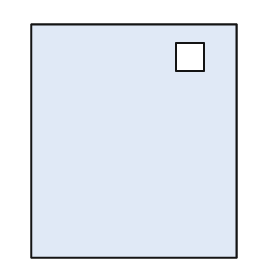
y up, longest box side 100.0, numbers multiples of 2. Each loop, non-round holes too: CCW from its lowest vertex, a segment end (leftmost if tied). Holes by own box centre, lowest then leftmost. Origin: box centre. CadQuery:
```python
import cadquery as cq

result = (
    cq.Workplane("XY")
    .moveTo(-44.0, -50.0)
    .lineTo(44.0, -50.0)
    .lineTo(44.0, 50.0)
    .lineTo(-44.0, 50.0)
    .close()
    .moveTo(18.0, 30.0)
    .lineTo(30.0, 30.0)
    .lineTo(30.0, 42.0)
    .lineTo(18.0, 42.0)
    .close()
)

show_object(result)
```